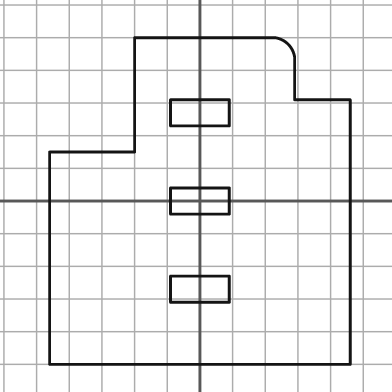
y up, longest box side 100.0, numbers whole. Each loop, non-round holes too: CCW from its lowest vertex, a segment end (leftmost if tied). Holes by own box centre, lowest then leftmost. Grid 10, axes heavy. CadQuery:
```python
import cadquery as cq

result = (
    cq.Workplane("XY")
    .moveTo(-46.0, -50.0)
    .lineTo(46.0, -50.0)
    .lineTo(46.0, 31.0)
    .lineTo(29.0, 31.0)
    .lineTo(29.0, 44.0)
    .threePointArc((27.0, 48.0), (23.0, 50.0))
    .lineTo(-20.0, 50.0)
    .lineTo(-20.0, 15.0)
    .lineTo(-46.0, 15.0)
    .close()
    .moveTo(-9.0, -31.0)
    .lineTo(9.0, -31.0)
    .lineTo(9.0, -23.0)
    .lineTo(-9.0, -23.0)
    .close()
    .moveTo(-9.0, -4.0)
    .lineTo(9.0, -4.0)
    .lineTo(9.0, 4.0)
    .lineTo(-9.0, 4.0)
    .close()
    .moveTo(-9.0, 23.0)
    .lineTo(9.0, 23.0)
    .lineTo(9.0, 31.0)
    .lineTo(-9.0, 31.0)
    .close()
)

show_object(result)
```